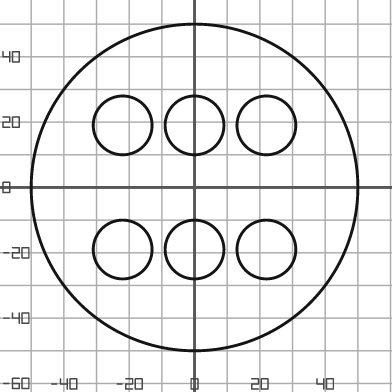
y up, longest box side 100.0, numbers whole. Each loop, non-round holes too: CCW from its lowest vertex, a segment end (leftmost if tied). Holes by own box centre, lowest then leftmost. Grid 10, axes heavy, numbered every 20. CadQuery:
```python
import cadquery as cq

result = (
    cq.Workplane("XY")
    .moveTo(0.0, 0.0)
    .circle(50.0)
    .moveTo(-22.0, -19.0)
    .circle(9.0)
    .moveTo(0.0, -19.0)
    .circle(9.0)
    .moveTo(22.0, -19.0)
    .circle(9.0)
    .moveTo(-22.0, 19.0)
    .circle(9.0)
    .moveTo(0.0, 19.0)
    .circle(9.0)
    .moveTo(22.0, 19.0)
    .circle(9.0)
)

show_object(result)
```